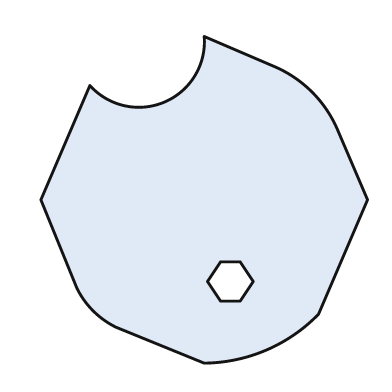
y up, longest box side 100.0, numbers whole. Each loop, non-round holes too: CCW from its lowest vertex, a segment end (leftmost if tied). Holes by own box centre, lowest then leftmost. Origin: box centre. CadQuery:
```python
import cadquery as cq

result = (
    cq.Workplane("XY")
    .moveTo(0.0, -50.0)
    .threePointArc((19.0, -46.0), (35.0, -35.0))
    .lineTo(50.0, 0.0)
    .lineTo(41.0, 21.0)
    .threePointArc((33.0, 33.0), (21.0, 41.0))
    .lineTo(0.0, 50.0)
    .threePointArc((-12.0, 30.0), (-35.0, 35.0))
    .lineTo(-50.0, 0.0)
    .lineTo(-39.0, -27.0)
    .threePointArc((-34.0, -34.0), (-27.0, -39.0))
    .close()
    .moveTo(5.0, -31.0)
    .lineTo(11.0, -31.0)
    .lineTo(15.0, -25.0)
    .lineTo(11.0, -19.0)
    .lineTo(5.0, -19.0)
    .lineTo(1.0, -25.0)
    .close()
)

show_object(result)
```